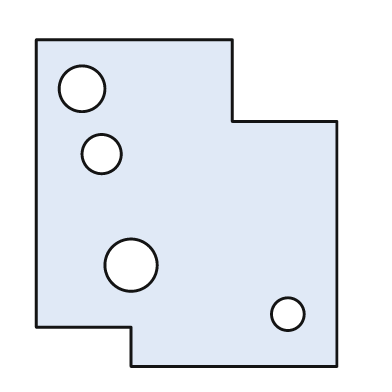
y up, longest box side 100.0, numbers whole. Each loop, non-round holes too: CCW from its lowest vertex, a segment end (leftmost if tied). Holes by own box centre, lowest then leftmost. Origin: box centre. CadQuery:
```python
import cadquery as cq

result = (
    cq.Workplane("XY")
    .moveTo(-17.0, -50.0)
    .lineTo(46.0, -50.0)
    .lineTo(46.0, 25.0)
    .lineTo(14.0, 25.0)
    .lineTo(14.0, 50.0)
    .lineTo(-46.0, 50.0)
    .lineTo(-46.0, -38.0)
    .lineTo(-17.0, -38.0)
    .close()
    .moveTo(31.0, -34.0)
    .circle(5.0)
    .moveTo(-17.0, -19.0)
    .circle(8.0)
    .moveTo(-26.0, 15.0)
    .circle(6.0)
    .moveTo(-32.0, 35.0)
    .circle(7.0)
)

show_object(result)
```